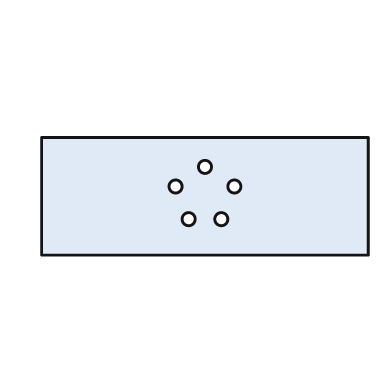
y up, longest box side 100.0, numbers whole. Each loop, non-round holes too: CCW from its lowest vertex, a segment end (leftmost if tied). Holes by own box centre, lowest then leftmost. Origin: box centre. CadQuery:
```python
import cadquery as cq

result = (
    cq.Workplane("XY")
    .moveTo(-50.0, -18.0)
    .lineTo(50.0, -18.0)
    .lineTo(50.0, 18.0)
    .lineTo(-50.0, 18.0)
    .close()
    .moveTo(-5.0, -7.0)
    .circle(2.0)
    .moveTo(5.0, -7.0)
    .circle(2.0)
    .moveTo(-9.0, 3.0)
    .circle(2.0)
    .moveTo(9.0, 3.0)
    .circle(2.0)
    .moveTo(0.0, 9.0)
    .circle(2.0)
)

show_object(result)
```